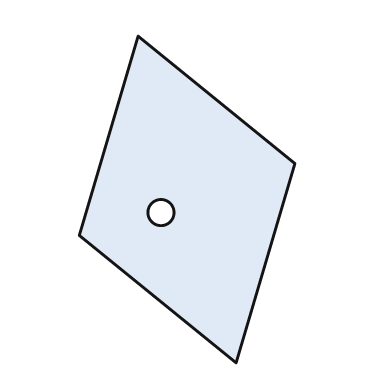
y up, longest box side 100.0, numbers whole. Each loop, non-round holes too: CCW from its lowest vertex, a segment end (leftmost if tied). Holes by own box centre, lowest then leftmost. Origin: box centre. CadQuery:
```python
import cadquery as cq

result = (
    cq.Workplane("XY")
    .moveTo(15.0, -50.0)
    .lineTo(33.0, 11.0)
    .lineTo(-15.0, 50.0)
    .lineTo(-33.0, -11.0)
    .close()
    .moveTo(-8.0, -4.0)
    .circle(4.0)
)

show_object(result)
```